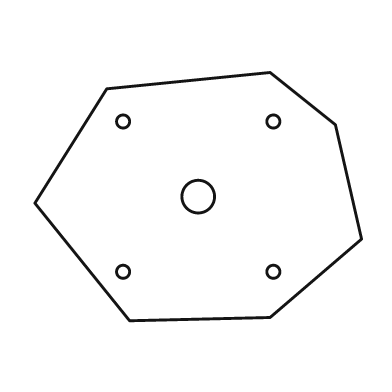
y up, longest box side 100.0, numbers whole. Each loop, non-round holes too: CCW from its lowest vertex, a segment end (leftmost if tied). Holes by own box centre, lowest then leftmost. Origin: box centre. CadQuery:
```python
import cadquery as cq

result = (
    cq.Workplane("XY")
    .moveTo(-21.0, -38.0)
    .lineTo(22.0, -37.0)
    .lineTo(50.0, -13.0)
    .lineTo(42.0, 22.0)
    .lineTo(22.0, 38.0)
    .lineTo(-28.0, 33.0)
    .lineTo(-50.0, -2.0)
    .close()
    .moveTo(-23.0, -23.0)
    .circle(2.0)
    .moveTo(23.0, -23.0)
    .circle(2.0)
    .moveTo(0.0, 0.0)
    .circle(5.0)
    .moveTo(-23.0, 23.0)
    .circle(2.0)
    .moveTo(23.0, 23.0)
    .circle(2.0)
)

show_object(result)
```